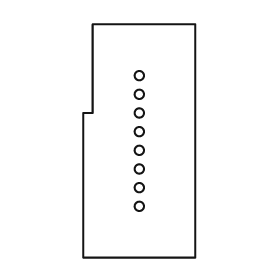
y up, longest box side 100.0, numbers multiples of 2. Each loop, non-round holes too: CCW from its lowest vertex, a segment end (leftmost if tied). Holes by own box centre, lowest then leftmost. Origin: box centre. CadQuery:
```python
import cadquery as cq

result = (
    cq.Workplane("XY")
    .moveTo(-24.0, -50.0)
    .lineTo(24.0, -50.0)
    .lineTo(24.0, 50.0)
    .lineTo(-20.0, 50.0)
    .lineTo(-20.0, 12.0)
    .lineTo(-24.0, 12.0)
    .close()
    .moveTo(0.0, -28.0)
    .circle(2.0)
    .moveTo(0.0, -20.0)
    .circle(2.0)
    .moveTo(0.0, -12.0)
    .circle(2.0)
    .moveTo(0.0, -4.0)
    .circle(2.0)
    .moveTo(0.0, 4.0)
    .circle(2.0)
    .moveTo(0.0, 12.0)
    .circle(2.0)
    .moveTo(0.0, 20.0)
    .circle(2.0)
    .moveTo(0.0, 28.0)
    .circle(2.0)
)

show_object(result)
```